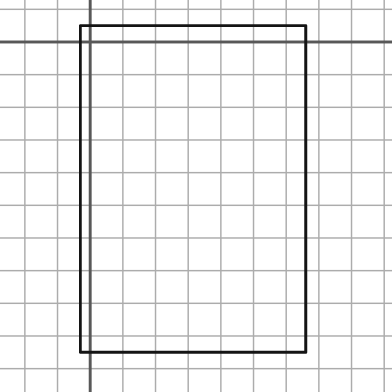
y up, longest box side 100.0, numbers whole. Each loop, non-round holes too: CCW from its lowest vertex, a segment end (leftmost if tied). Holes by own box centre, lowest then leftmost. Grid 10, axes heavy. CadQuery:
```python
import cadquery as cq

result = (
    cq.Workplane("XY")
    .moveTo(-3.0, -95.0)
    .lineTo(66.0, -95.0)
    .lineTo(66.0, 5.0)
    .lineTo(-3.0, 5.0)
    .close()
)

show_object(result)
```